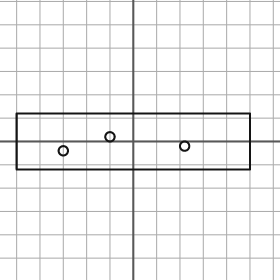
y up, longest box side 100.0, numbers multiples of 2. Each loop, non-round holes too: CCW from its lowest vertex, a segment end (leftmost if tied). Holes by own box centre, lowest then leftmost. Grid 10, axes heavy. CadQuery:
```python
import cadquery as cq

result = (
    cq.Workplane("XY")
    .moveTo(-50.0, -12.0)
    .lineTo(50.0, -12.0)
    .lineTo(50.0, 12.0)
    .lineTo(-50.0, 12.0)
    .close()
    .moveTo(-30.0, -4.0)
    .circle(2.0)
    .moveTo(22.0, -2.0)
    .circle(2.0)
    .moveTo(-10.0, 2.0)
    .circle(2.0)
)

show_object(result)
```